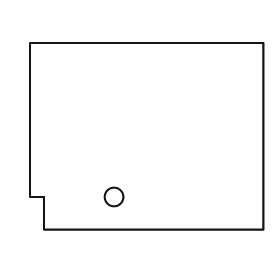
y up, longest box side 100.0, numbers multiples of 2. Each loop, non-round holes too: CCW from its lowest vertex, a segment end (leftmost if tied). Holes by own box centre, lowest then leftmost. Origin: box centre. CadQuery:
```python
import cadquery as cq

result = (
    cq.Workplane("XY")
    .moveTo(-44.0, -40.0)
    .lineTo(50.0, -40.0)
    .lineTo(50.0, 40.0)
    .lineTo(-50.0, 40.0)
    .lineTo(-50.0, -26.0)
    .lineTo(-44.0, -26.0)
    .close()
    .moveTo(-14.0, -26.0)
    .circle(4.0)
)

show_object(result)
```